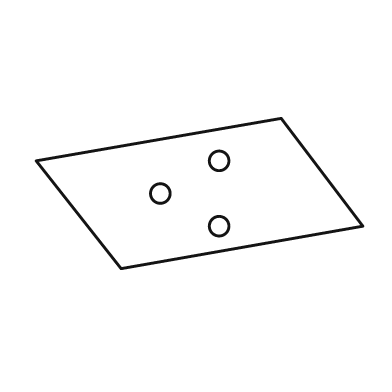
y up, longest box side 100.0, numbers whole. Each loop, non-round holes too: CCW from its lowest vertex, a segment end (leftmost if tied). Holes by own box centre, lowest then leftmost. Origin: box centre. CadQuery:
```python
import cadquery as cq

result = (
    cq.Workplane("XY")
    .moveTo(-24.0, -23.0)
    .lineTo(50.0, -10.0)
    .lineTo(25.0, 23.0)
    .lineTo(-50.0, 10.0)
    .close()
    .moveTo(6.0, -10.0)
    .circle(3.0)
    .moveTo(-12.0, 0.0)
    .circle(3.0)
    .moveTo(6.0, 10.0)
    .circle(3.0)
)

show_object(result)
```